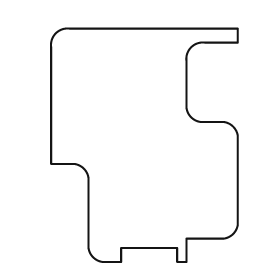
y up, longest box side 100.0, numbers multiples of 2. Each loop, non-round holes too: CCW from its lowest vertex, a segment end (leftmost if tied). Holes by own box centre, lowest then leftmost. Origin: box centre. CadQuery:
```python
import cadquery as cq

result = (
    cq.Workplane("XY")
    .moveTo(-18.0, -50.0)
    .lineTo(-10.0, -50.0)
    .lineTo(-10.0, -44.0)
    .lineTo(14.0, -44.0)
    .lineTo(14.0, -50.0)
    .lineTo(18.0, -50.0)
    .lineTo(18.0, -40.0)
    .lineTo(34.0, -40.0)
    .threePointArc((38.0, -38.0), (40.0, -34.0))
    .lineTo(40.0, 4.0)
    .threePointArc((38.0, 8.0), (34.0, 10.0))
    .lineTo(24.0, 10.0)
    .threePointArc((20.0, 12.0), (18.0, 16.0))
    .lineTo(18.0, 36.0)
    .threePointArc((20.0, 42.0), (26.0, 44.0))
    .lineTo(40.0, 44.0)
    .lineTo(40.0, 50.0)
    .lineTo(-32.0, 50.0)
    .threePointArc((-38.0, 48.0), (-40.0, 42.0))
    .lineTo(-40.0, -8.0)
    .lineTo(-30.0, -8.0)
    .threePointArc((-26.0, -10.0), (-24.0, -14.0))
    .lineTo(-24.0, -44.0)
    .threePointArc((-22.0, -48.0), (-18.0, -50.0))
    .close()
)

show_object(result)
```